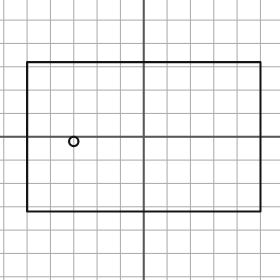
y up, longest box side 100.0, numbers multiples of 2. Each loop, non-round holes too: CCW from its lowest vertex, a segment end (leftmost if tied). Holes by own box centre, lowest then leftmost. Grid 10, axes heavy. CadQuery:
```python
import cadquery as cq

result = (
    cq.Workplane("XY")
    .moveTo(-50.0, -32.0)
    .lineTo(50.0, -32.0)
    .lineTo(50.0, 32.0)
    .lineTo(-50.0, 32.0)
    .close()
    .moveTo(-30.0, -2.0)
    .circle(2.0)
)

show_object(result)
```